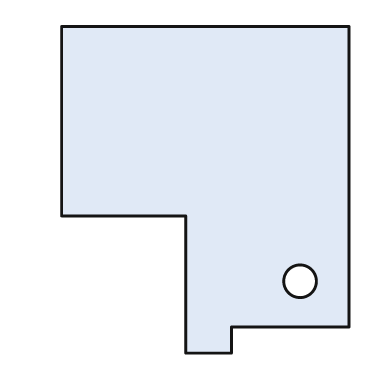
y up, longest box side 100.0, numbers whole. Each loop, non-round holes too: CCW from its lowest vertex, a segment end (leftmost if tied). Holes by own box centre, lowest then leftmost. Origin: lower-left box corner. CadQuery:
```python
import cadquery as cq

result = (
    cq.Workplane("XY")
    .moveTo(38.0, 0.0)
    .lineTo(52.0, 0.0)
    .lineTo(52.0, 8.0)
    .lineTo(88.0, 8.0)
    .lineTo(88.0, 100.0)
    .lineTo(0.0, 100.0)
    .lineTo(0.0, 42.0)
    .lineTo(38.0, 42.0)
    .close()
    .moveTo(73.0, 22.0)
    .circle(5.0)
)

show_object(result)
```